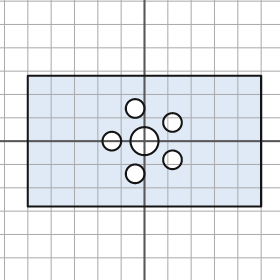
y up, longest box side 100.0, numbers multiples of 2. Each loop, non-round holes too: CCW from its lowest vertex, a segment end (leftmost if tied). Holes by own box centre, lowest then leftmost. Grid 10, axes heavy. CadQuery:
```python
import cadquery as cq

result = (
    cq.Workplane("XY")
    .moveTo(-50.0, -28.0)
    .lineTo(50.0, -28.0)
    .lineTo(50.0, 28.0)
    .lineTo(-50.0, 28.0)
    .close()
    .moveTo(-4.0, -14.0)
    .circle(4.0)
    .moveTo(12.0, -8.0)
    .circle(4.0)
    .moveTo(-14.0, 0.0)
    .circle(4.0)
    .moveTo(0.0, 0.0)
    .circle(6.0)
    .moveTo(12.0, 8.0)
    .circle(4.0)
    .moveTo(-4.0, 14.0)
    .circle(4.0)
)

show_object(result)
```